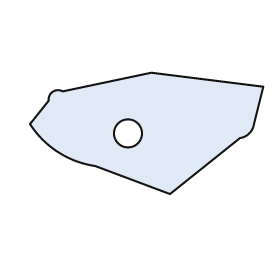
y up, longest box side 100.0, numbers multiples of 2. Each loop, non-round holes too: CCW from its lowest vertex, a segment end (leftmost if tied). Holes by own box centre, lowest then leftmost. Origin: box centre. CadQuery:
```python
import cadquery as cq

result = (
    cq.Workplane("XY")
    .moveTo(10.0, -26.0)
    .lineTo(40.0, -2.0)
    .threePointArc((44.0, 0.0), (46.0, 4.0))
    .lineTo(50.0, 20.0)
    .lineTo(2.0, 26.0)
    .lineTo(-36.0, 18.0)
    .threePointArc((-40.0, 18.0), (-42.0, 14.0))
    .lineTo(-50.0, 4.0)
    .threePointArc((-38.0, -8.0), (-22.0, -14.0))
    .close()
    .moveTo(-8.0, 0.0)
    .circle(6.0)
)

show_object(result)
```